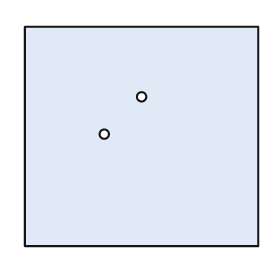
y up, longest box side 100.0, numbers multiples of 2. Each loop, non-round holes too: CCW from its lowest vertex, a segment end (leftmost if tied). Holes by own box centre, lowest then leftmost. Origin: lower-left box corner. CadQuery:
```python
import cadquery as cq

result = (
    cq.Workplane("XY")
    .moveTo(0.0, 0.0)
    .lineTo(100.0, 0.0)
    .lineTo(100.0, 94.0)
    .lineTo(0.0, 94.0)
    .close()
    .moveTo(34.0, 48.0)
    .circle(2.0)
    .moveTo(50.0, 64.0)
    .circle(2.0)
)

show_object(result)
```